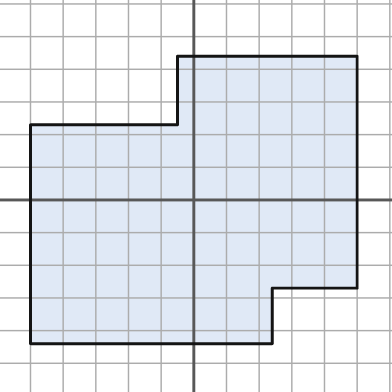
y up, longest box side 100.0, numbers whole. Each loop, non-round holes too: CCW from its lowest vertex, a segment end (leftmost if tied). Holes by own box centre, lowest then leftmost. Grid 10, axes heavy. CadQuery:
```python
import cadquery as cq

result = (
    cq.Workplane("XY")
    .moveTo(-50.0, -44.0)
    .lineTo(24.0, -44.0)
    .lineTo(24.0, -27.0)
    .lineTo(50.0, -27.0)
    .lineTo(50.0, 44.0)
    .lineTo(-5.0, 44.0)
    .lineTo(-5.0, 23.0)
    .lineTo(-50.0, 23.0)
    .close()
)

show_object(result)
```